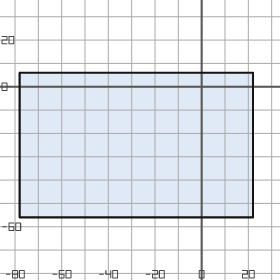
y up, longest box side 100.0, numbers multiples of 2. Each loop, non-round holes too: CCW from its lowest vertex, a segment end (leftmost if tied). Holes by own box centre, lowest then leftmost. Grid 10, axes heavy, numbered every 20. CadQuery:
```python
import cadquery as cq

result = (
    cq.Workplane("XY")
    .moveTo(-78.0, -56.0)
    .lineTo(22.0, -56.0)
    .lineTo(22.0, 6.0)
    .lineTo(-78.0, 6.0)
    .close()
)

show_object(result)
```